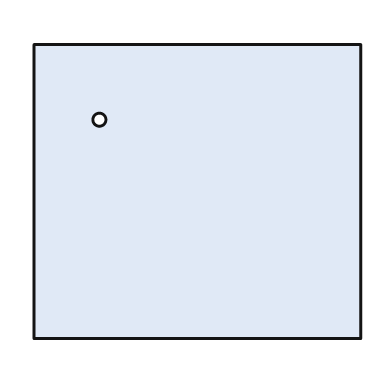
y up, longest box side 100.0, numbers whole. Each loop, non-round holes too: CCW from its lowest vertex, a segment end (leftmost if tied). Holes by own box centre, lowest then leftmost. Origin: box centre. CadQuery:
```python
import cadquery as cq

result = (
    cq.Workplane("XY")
    .moveTo(-50.0, -45.0)
    .lineTo(50.0, -45.0)
    .lineTo(50.0, 45.0)
    .lineTo(-50.0, 45.0)
    .close()
    .moveTo(-30.0, 22.0)
    .circle(2.0)
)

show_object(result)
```